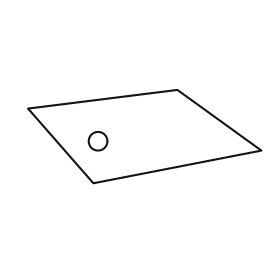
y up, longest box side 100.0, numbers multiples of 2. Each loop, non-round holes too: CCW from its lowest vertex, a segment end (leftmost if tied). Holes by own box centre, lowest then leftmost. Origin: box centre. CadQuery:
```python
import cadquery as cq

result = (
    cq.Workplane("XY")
    .moveTo(-22.0, -20.0)
    .lineTo(50.0, -6.0)
    .lineTo(14.0, 20.0)
    .lineTo(-50.0, 12.0)
    .close()
    .moveTo(-20.0, -2.0)
    .circle(4.0)
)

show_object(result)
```